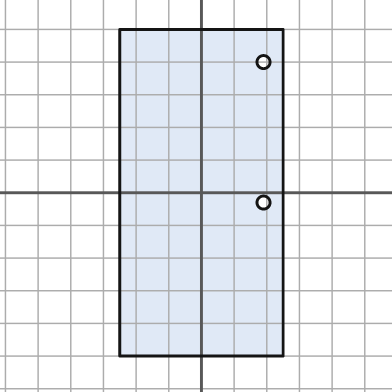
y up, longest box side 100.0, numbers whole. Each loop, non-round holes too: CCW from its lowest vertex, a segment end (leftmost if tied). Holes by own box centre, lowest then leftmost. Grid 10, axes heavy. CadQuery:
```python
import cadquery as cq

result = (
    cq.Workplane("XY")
    .moveTo(-25.0, -50.0)
    .lineTo(25.0, -50.0)
    .lineTo(25.0, 50.0)
    .lineTo(-25.0, 50.0)
    .close()
    .moveTo(19.0, -3.0)
    .circle(2.0)
    .moveTo(19.0, 40.0)
    .circle(2.0)
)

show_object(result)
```